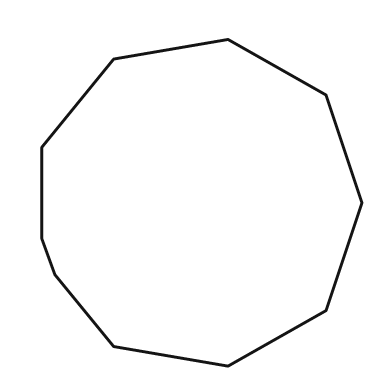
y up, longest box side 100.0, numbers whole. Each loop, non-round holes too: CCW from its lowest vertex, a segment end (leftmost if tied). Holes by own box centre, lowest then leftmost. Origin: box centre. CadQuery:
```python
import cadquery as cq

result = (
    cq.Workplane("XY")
    .moveTo(8.0, -50.0)
    .lineTo(38.0, -33.0)
    .lineTo(49.0, 0.0)
    .lineTo(38.0, 33.0)
    .lineTo(8.0, 50.0)
    .lineTo(-27.0, 44.0)
    .lineTo(-49.0, 17.0)
    .lineTo(-49.0, -11.0)
    .lineTo(-45.0, -22.0)
    .lineTo(-27.0, -44.0)
    .close()
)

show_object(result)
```